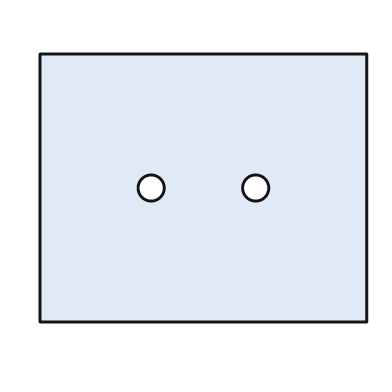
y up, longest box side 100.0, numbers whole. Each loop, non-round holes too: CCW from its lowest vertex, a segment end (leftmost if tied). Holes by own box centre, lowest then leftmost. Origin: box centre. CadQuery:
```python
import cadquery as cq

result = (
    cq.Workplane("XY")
    .moveTo(-50.0, -41.0)
    .lineTo(50.0, -41.0)
    .lineTo(50.0, 41.0)
    .lineTo(-50.0, 41.0)
    .close()
    .moveTo(-16.0, 0.0)
    .circle(4.0)
    .moveTo(16.0, 0.0)
    .circle(4.0)
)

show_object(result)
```